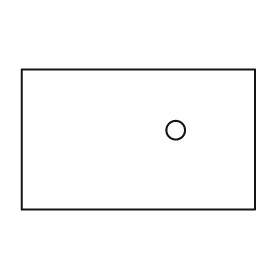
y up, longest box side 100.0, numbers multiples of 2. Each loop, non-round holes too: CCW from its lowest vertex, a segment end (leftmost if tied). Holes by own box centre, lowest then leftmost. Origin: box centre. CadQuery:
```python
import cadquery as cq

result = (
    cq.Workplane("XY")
    .moveTo(-50.0, -30.0)
    .lineTo(50.0, -30.0)
    .lineTo(50.0, 30.0)
    .lineTo(-50.0, 30.0)
    .close()
    .moveTo(16.0, 4.0)
    .circle(4.0)
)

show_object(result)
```